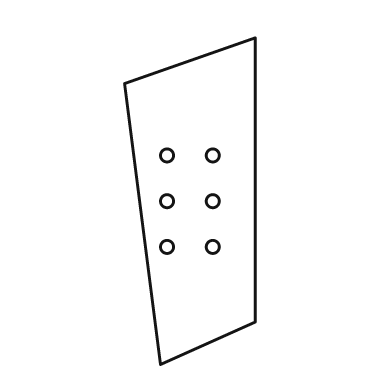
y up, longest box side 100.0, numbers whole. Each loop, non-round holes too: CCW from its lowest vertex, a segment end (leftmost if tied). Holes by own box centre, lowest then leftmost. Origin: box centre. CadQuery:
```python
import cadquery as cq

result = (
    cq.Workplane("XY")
    .moveTo(-9.0, -50.0)
    .lineTo(20.0, -37.0)
    .lineTo(20.0, 50.0)
    .lineTo(-20.0, 36.0)
    .close()
    .moveTo(-7.0, -14.0)
    .circle(2.0)
    .moveTo(7.0, -14.0)
    .circle(2.0)
    .moveTo(-7.0, 0.0)
    .circle(2.0)
    .moveTo(7.0, 0.0)
    .circle(2.0)
    .moveTo(-7.0, 14.0)
    .circle(2.0)
    .moveTo(7.0, 14.0)
    .circle(2.0)
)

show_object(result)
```